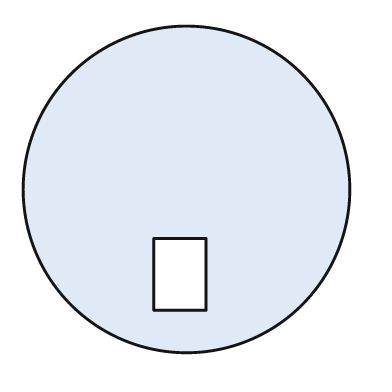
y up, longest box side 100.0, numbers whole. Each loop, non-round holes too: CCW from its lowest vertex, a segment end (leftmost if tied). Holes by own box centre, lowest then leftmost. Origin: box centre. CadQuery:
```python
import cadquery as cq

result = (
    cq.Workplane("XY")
    .moveTo(0.0, 0.0)
    .circle(50.0)
    .moveTo(-10.0, -37.0)
    .lineTo(6.0, -37.0)
    .lineTo(6.0, -15.0)
    .lineTo(-10.0, -15.0)
    .close()
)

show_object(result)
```